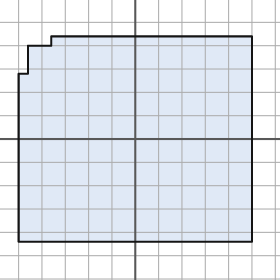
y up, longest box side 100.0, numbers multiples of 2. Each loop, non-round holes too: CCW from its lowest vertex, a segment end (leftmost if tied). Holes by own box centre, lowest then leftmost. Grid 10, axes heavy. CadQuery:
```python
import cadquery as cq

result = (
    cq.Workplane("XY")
    .moveTo(-50.0, -44.0)
    .lineTo(50.0, -44.0)
    .lineTo(50.0, 44.0)
    .lineTo(-36.0, 44.0)
    .lineTo(-36.0, 40.0)
    .lineTo(-46.0, 40.0)
    .lineTo(-46.0, 28.0)
    .lineTo(-50.0, 28.0)
    .close()
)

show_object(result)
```